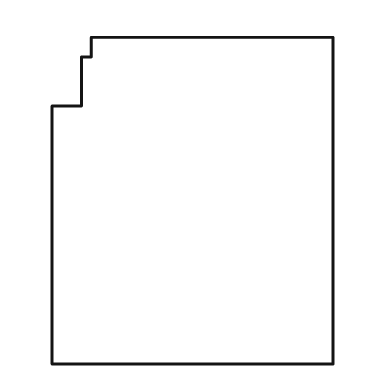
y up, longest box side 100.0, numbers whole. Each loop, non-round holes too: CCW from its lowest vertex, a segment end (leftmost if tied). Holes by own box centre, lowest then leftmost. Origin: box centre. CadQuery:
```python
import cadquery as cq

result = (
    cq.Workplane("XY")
    .moveTo(-43.0, -50.0)
    .lineTo(43.0, -50.0)
    .lineTo(43.0, 50.0)
    .lineTo(-31.0, 50.0)
    .lineTo(-31.0, 44.0)
    .lineTo(-34.0, 44.0)
    .lineTo(-34.0, 29.0)
    .lineTo(-43.0, 29.0)
    .close()
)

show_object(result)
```